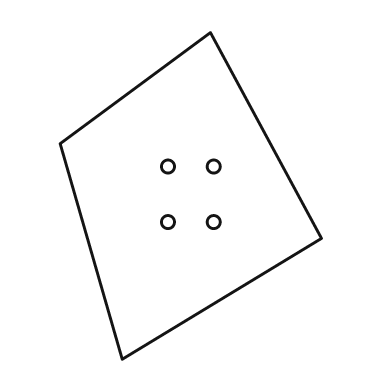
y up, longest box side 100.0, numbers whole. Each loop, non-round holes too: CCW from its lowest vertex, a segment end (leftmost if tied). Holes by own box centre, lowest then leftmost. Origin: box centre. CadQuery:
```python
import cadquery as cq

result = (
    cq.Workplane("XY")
    .moveTo(-21.0, -50.0)
    .lineTo(40.0, -13.0)
    .lineTo(6.0, 50.0)
    .lineTo(-40.0, 16.0)
    .close()
    .moveTo(-7.0, -8.0)
    .circle(2.0)
    .moveTo(7.0, -8.0)
    .circle(2.0)
    .moveTo(-7.0, 9.0)
    .circle(2.0)
    .moveTo(7.0, 9.0)
    .circle(2.0)
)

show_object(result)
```